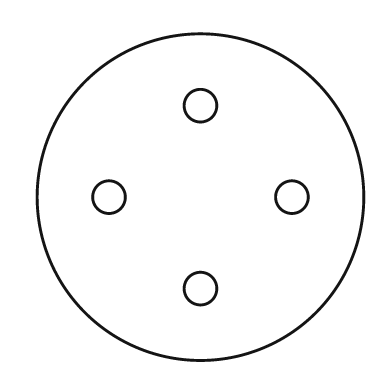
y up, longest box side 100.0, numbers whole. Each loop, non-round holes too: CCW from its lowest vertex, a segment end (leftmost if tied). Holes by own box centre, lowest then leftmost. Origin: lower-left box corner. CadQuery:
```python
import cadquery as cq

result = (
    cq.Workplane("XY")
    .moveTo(50.0, 50.0)
    .circle(50.0)
    .moveTo(50.0, 22.0)
    .circle(5.0)
    .moveTo(22.0, 50.0)
    .circle(5.0)
    .moveTo(78.0, 50.0)
    .circle(5.0)
    .moveTo(50.0, 78.0)
    .circle(5.0)
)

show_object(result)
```